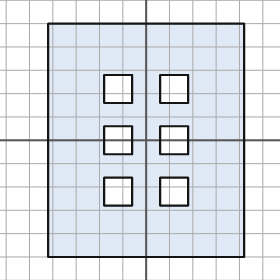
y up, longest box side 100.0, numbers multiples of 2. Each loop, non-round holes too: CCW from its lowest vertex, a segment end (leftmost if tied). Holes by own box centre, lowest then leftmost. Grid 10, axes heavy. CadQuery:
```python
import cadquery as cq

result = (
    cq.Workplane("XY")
    .moveTo(-42.0, -50.0)
    .lineTo(42.0, -50.0)
    .lineTo(42.0, 50.0)
    .lineTo(-42.0, 50.0)
    .close()
    .moveTo(-18.0, -28.0)
    .lineTo(-6.0, -28.0)
    .lineTo(-6.0, -16.0)
    .lineTo(-18.0, -16.0)
    .close()
    .moveTo(6.0, -28.0)
    .lineTo(18.0, -28.0)
    .lineTo(18.0, -16.0)
    .lineTo(6.0, -16.0)
    .close()
    .moveTo(-18.0, -6.0)
    .lineTo(-6.0, -6.0)
    .lineTo(-6.0, 6.0)
    .lineTo(-18.0, 6.0)
    .close()
    .moveTo(6.0, -6.0)
    .lineTo(18.0, -6.0)
    .lineTo(18.0, 6.0)
    .lineTo(6.0, 6.0)
    .close()
    .moveTo(-18.0, 16.0)
    .lineTo(-6.0, 16.0)
    .lineTo(-6.0, 28.0)
    .lineTo(-18.0, 28.0)
    .close()
    .moveTo(6.0, 16.0)
    .lineTo(18.0, 16.0)
    .lineTo(18.0, 28.0)
    .lineTo(6.0, 28.0)
    .close()
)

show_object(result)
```